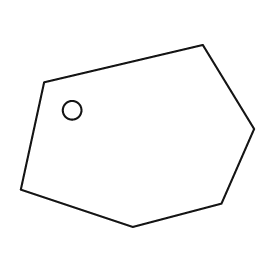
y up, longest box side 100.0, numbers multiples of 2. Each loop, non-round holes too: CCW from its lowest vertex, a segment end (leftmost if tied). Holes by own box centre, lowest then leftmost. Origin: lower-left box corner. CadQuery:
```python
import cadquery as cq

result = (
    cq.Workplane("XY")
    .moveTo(48.0, 0.0)
    .lineTo(86.0, 10.0)
    .lineTo(100.0, 42.0)
    .lineTo(78.0, 78.0)
    .lineTo(10.0, 62.0)
    .lineTo(0.0, 16.0)
    .close()
    .moveTo(22.0, 50.0)
    .circle(4.0)
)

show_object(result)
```